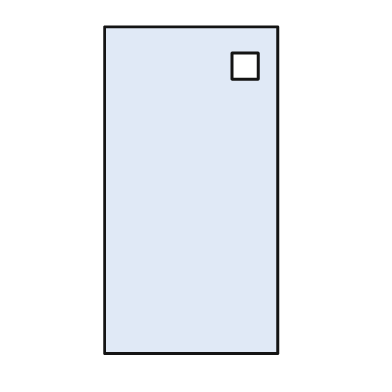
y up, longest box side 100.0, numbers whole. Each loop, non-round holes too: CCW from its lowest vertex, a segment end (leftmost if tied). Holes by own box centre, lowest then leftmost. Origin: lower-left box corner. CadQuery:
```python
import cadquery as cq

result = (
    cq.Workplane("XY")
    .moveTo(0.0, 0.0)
    .lineTo(53.0, 0.0)
    .lineTo(53.0, 100.0)
    .lineTo(0.0, 100.0)
    .close()
    .moveTo(39.0, 84.0)
    .lineTo(47.0, 84.0)
    .lineTo(47.0, 92.0)
    .lineTo(39.0, 92.0)
    .close()
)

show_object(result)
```